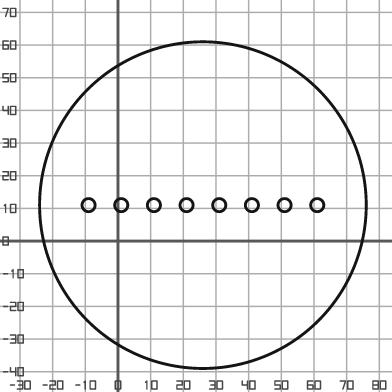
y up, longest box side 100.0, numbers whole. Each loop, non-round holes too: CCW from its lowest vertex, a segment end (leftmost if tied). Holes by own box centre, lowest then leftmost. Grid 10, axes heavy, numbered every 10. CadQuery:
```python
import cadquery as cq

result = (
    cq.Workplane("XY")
    .moveTo(26.0, 11.0)
    .circle(50.0)
    .moveTo(-9.0, 11.0)
    .circle(2.0)
    .moveTo(1.0, 11.0)
    .circle(2.0)
    .moveTo(11.0, 11.0)
    .circle(2.0)
    .moveTo(21.0, 11.0)
    .circle(2.0)
    .moveTo(31.0, 11.0)
    .circle(2.0)
    .moveTo(41.0, 11.0)
    .circle(2.0)
    .moveTo(51.0, 11.0)
    .circle(2.0)
    .moveTo(61.0, 11.0)
    .circle(2.0)
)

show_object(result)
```